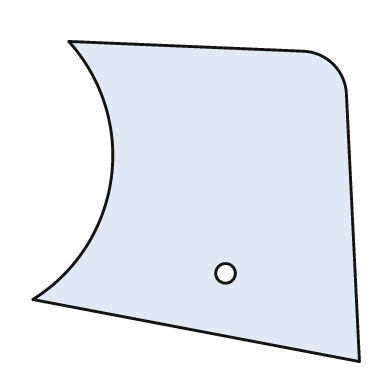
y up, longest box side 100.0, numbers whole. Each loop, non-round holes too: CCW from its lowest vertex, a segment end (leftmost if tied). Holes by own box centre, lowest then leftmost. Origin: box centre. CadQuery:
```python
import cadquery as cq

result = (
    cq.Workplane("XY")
    .moveTo(50.0, -49.0)
    .lineTo(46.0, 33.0)
    .threePointArc((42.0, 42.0), (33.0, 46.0))
    .lineTo(-39.0, 49.0)
    .threePointArc((-26.0, 7.0), (-50.0, -30.0))
    .close()
    .moveTo(9.0, -22.0)
    .circle(3.0)
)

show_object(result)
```